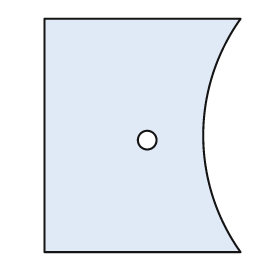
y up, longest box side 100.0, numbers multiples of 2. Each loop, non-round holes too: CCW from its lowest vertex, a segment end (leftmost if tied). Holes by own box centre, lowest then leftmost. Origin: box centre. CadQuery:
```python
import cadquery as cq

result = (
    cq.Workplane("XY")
    .moveTo(-42.0, -50.0)
    .lineTo(42.0, -50.0)
    .threePointArc((26.0, 0.0), (42.0, 50.0))
    .lineTo(-42.0, 50.0)
    .close()
    .moveTo(2.0, -2.0)
    .circle(4.0)
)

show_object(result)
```